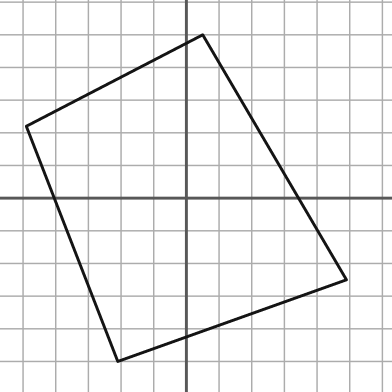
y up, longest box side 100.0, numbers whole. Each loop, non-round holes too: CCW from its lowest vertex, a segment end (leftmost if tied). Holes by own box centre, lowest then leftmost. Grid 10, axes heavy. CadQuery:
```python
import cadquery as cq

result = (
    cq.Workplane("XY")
    .moveTo(-21.0, -50.0)
    .lineTo(49.0, -25.0)
    .lineTo(5.0, 50.0)
    .lineTo(-49.0, 22.0)
    .close()
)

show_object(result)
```